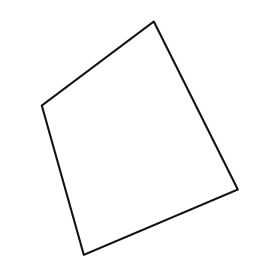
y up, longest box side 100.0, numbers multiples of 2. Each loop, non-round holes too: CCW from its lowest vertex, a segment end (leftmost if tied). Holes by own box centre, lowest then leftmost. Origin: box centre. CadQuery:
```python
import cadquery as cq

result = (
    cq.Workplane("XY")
    .moveTo(-24.0, -50.0)
    .lineTo(42.0, -22.0)
    .lineTo(6.0, 50.0)
    .lineTo(-42.0, 14.0)
    .close()
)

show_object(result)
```